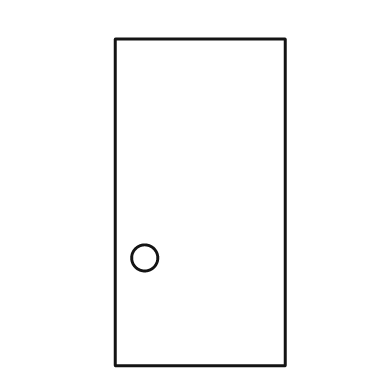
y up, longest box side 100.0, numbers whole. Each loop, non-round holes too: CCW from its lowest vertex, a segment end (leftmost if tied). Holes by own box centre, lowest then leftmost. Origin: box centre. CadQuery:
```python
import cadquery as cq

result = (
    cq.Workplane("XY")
    .moveTo(-26.0, -50.0)
    .lineTo(26.0, -50.0)
    .lineTo(26.0, 50.0)
    .lineTo(-26.0, 50.0)
    .close()
    .moveTo(-17.0, -17.0)
    .circle(4.0)
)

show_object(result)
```